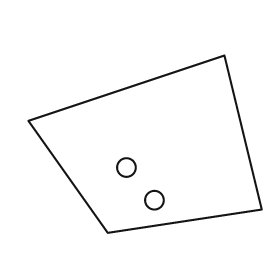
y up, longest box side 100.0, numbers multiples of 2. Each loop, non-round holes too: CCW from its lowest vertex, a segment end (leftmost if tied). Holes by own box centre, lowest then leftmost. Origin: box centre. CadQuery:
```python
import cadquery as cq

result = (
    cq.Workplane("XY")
    .moveTo(-16.0, -38.0)
    .lineTo(50.0, -28.0)
    .lineTo(34.0, 38.0)
    .lineTo(-50.0, 10.0)
    .close()
    .moveTo(4.0, -24.0)
    .circle(4.0)
    .moveTo(-8.0, -10.0)
    .circle(4.0)
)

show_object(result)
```